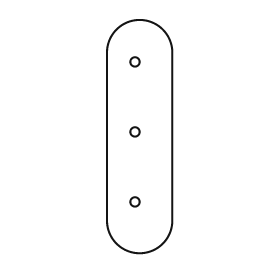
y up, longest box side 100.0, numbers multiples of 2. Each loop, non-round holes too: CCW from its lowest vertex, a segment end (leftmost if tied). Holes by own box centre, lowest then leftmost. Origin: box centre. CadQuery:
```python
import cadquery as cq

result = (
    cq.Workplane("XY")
    .moveTo(-14.0, -36.0)
    .threePointArc((0.0, -50.0), (14.0, -36.0))
    .lineTo(14.0, 36.0)
    .threePointArc((0.0, 50.0), (-14.0, 36.0))
    .close()
    .moveTo(-2.0, -28.0)
    .circle(2.0)
    .moveTo(-2.0, 2.0)
    .circle(2.0)
    .moveTo(-2.0, 32.0)
    .circle(2.0)
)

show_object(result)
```